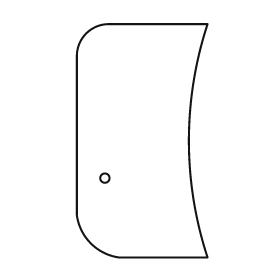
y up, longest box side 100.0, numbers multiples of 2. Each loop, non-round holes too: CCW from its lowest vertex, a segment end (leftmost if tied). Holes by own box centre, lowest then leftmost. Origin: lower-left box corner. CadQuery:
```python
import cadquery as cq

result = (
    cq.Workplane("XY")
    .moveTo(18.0, 0.0)
    .lineTo(56.0, 0.0)
    .threePointArc((48.0, 50.0), (56.0, 100.0))
    .lineTo(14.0, 100.0)
    .threePointArc((4.0, 96.0), (0.0, 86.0))
    .lineTo(0.0, 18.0)
    .threePointArc((6.0, 6.0), (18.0, 0.0))
    .close()
    .moveTo(12.0, 34.0)
    .circle(2.0)
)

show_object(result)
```